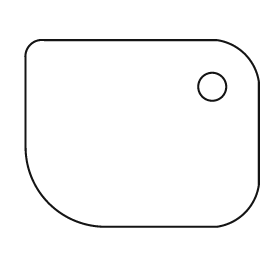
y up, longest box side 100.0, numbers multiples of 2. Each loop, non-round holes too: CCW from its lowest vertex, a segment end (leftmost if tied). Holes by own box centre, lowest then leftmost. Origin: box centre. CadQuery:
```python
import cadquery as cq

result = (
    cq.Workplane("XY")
    .moveTo(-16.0, -40.0)
    .lineTo(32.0, -40.0)
    .threePointArc((44.0, -34.0), (50.0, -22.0))
    .lineTo(50.0, 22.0)
    .threePointArc((44.0, 34.0), (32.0, 40.0))
    .lineTo(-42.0, 40.0)
    .threePointArc((-48.0, 38.0), (-50.0, 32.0))
    .lineTo(-50.0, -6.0)
    .threePointArc((-40.0, -30.0), (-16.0, -40.0))
    .close()
    .moveTo(30.0, 20.0)
    .circle(6.0)
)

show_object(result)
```